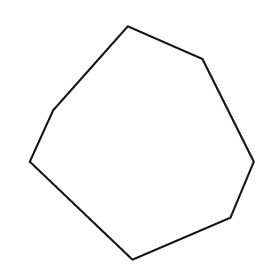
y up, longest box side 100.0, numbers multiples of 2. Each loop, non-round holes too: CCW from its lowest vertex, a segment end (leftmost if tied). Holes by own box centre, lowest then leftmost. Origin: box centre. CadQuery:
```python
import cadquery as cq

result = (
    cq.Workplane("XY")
    .moveTo(-4.0, -50.0)
    .lineTo(38.0, -32.0)
    .lineTo(48.0, -8.0)
    .lineTo(26.0, 36.0)
    .lineTo(-6.0, 50.0)
    .lineTo(-38.0, 14.0)
    .lineTo(-48.0, -8.0)
    .close()
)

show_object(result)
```